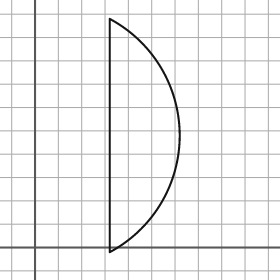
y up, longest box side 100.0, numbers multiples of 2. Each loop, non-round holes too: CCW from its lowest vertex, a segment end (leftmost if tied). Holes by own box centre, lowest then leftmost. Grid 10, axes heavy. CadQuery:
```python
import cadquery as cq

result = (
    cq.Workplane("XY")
    .moveTo(32.0, -2.0)
    .threePointArc((62.0, 48.0), (32.0, 98.0))
    .close()
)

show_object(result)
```